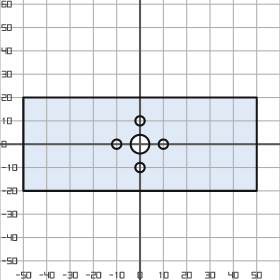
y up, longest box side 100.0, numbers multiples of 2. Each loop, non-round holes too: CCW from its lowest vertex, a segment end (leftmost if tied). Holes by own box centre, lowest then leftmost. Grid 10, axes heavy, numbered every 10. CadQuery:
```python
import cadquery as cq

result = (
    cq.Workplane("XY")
    .moveTo(-50.0, -20.0)
    .lineTo(50.0, -20.0)
    .lineTo(50.0, 20.0)
    .lineTo(-50.0, 20.0)
    .close()
    .moveTo(0.0, -10.0)
    .circle(2.0)
    .moveTo(-10.0, 0.0)
    .circle(2.0)
    .moveTo(0.0, 0.0)
    .circle(4.0)
    .moveTo(10.0, 0.0)
    .circle(2.0)
    .moveTo(0.0, 10.0)
    .circle(2.0)
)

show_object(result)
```